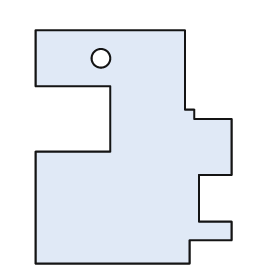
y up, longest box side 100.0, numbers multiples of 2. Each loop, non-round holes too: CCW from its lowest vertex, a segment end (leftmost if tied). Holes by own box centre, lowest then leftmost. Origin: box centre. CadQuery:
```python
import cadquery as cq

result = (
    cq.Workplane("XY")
    .moveTo(-42.0, -50.0)
    .lineTo(24.0, -50.0)
    .lineTo(24.0, -40.0)
    .lineTo(42.0, -40.0)
    .lineTo(42.0, -32.0)
    .lineTo(28.0, -32.0)
    .lineTo(28.0, -12.0)
    .lineTo(42.0, -12.0)
    .lineTo(42.0, 12.0)
    .lineTo(26.0, 12.0)
    .lineTo(26.0, 16.0)
    .lineTo(22.0, 16.0)
    .lineTo(22.0, 50.0)
    .lineTo(-42.0, 50.0)
    .lineTo(-42.0, 26.0)
    .lineTo(-10.0, 26.0)
    .lineTo(-10.0, -2.0)
    .lineTo(-42.0, -2.0)
    .close()
    .moveTo(-14.0, 38.0)
    .circle(4.0)
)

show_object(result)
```